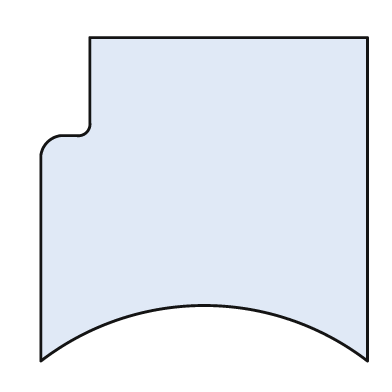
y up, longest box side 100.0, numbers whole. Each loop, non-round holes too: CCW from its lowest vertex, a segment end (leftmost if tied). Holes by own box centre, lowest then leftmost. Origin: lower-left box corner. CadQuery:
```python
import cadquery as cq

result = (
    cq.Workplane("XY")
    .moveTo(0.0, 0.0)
    .threePointArc((50.0, 17.0), (100.0, 0.0))
    .lineTo(100.0, 99.0)
    .lineTo(15.0, 99.0)
    .lineTo(15.0, 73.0)
    .threePointArc((14.0, 70.0), (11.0, 69.0))
    .lineTo(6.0, 69.0)
    .threePointArc((2.0, 67.0), (0.0, 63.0))
    .close()
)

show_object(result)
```